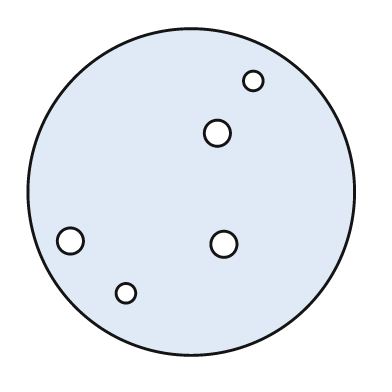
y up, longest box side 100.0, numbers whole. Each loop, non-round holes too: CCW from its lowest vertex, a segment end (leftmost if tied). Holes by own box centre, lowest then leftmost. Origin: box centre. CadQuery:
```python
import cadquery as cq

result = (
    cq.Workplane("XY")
    .moveTo(0.0, 0.0)
    .circle(50.0)
    .moveTo(-20.0, -31.0)
    .circle(3.0)
    .moveTo(10.0, -16.0)
    .circle(4.0)
    .moveTo(-37.0, -15.0)
    .circle(4.0)
    .moveTo(8.0, 18.0)
    .circle(4.0)
    .moveTo(19.0, 34.0)
    .circle(3.0)
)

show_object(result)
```